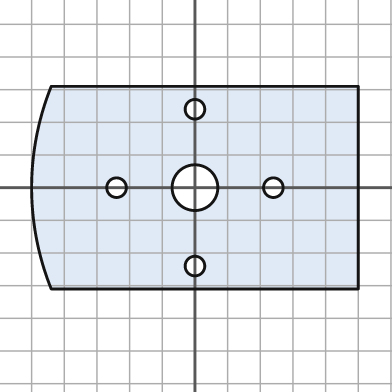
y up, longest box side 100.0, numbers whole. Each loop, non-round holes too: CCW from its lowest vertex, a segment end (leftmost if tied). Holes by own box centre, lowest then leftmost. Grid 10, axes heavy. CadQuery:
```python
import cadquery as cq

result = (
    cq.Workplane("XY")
    .moveTo(-44.0, -31.0)
    .lineTo(50.0, -31.0)
    .lineTo(50.0, 31.0)
    .lineTo(-44.0, 31.0)
    .threePointArc((-50.0, 0.0), (-44.0, -31.0))
    .close()
    .moveTo(0.0, -24.0)
    .circle(3.0)
    .moveTo(-24.0, 0.0)
    .circle(3.0)
    .moveTo(0.0, 0.0)
    .circle(7.0)
    .moveTo(24.0, 0.0)
    .circle(3.0)
    .moveTo(0.0, 24.0)
    .circle(3.0)
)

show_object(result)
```